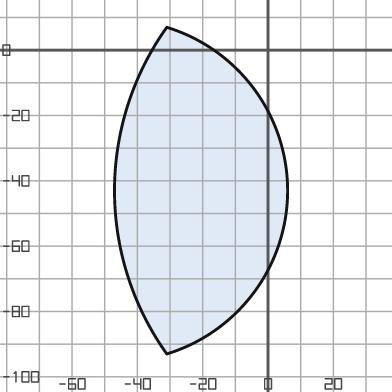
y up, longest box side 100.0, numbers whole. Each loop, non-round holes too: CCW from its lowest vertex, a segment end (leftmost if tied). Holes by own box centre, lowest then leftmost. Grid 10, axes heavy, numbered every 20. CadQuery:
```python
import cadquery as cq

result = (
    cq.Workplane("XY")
    .moveTo(-31.0, -93.0)
    .threePointArc((6.0, -43.0), (-31.0, 7.0))
    .threePointArc((-47.0, -43.0), (-31.0, -93.0))
    .close()
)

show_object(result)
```